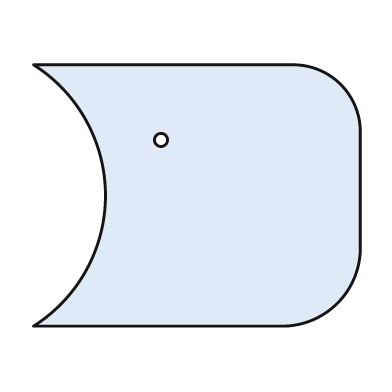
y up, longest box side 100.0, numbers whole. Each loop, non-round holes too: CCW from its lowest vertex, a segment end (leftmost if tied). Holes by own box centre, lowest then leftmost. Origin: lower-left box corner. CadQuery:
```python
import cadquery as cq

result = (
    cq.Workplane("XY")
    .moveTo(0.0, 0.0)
    .lineTo(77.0, 0.0)
    .threePointArc((93.0, 7.0), (100.0, 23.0))
    .lineTo(100.0, 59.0)
    .threePointArc((94.0, 74.0), (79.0, 80.0))
    .lineTo(0.0, 80.0)
    .threePointArc((22.0, 40.0), (0.0, 0.0))
    .close()
    .moveTo(39.0, 57.0)
    .circle(2.0)
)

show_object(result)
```